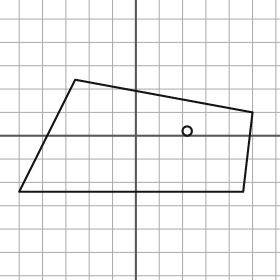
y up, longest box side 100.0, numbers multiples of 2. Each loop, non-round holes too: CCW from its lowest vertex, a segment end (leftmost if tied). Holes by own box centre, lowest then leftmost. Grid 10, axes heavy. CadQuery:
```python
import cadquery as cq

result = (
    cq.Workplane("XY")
    .moveTo(-50.0, -24.0)
    .lineTo(46.0, -24.0)
    .lineTo(50.0, 10.0)
    .lineTo(-26.0, 24.0)
    .close()
    .moveTo(22.0, 2.0)
    .circle(2.0)
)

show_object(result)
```